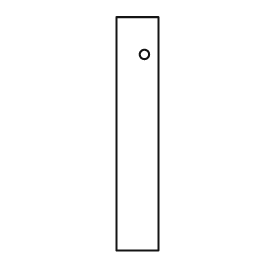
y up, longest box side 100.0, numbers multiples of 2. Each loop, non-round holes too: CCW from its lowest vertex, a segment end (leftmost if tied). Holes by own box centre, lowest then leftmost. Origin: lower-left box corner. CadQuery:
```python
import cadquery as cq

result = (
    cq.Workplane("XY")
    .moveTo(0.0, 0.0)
    .lineTo(18.0, 0.0)
    .lineTo(18.0, 100.0)
    .lineTo(0.0, 100.0)
    .close()
    .moveTo(12.0, 84.0)
    .circle(2.0)
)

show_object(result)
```